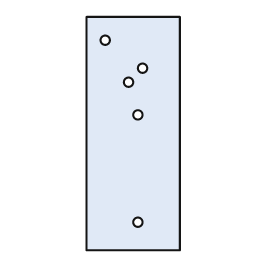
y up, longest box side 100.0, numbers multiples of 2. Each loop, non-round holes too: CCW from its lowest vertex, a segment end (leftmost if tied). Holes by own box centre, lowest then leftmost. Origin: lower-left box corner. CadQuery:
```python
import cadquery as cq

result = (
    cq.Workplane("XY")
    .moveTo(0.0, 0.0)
    .lineTo(40.0, 0.0)
    .lineTo(40.0, 100.0)
    .lineTo(0.0, 100.0)
    .close()
    .moveTo(22.0, 12.0)
    .circle(2.0)
    .moveTo(22.0, 58.0)
    .circle(2.0)
    .moveTo(18.0, 72.0)
    .circle(2.0)
    .moveTo(24.0, 78.0)
    .circle(2.0)
    .moveTo(8.0, 90.0)
    .circle(2.0)
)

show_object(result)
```